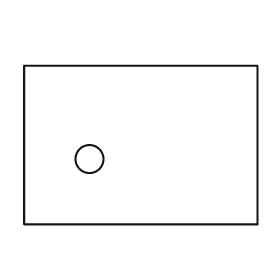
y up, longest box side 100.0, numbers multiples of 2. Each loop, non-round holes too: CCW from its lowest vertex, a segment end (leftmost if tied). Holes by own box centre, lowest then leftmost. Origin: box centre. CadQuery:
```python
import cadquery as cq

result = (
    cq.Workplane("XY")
    .moveTo(-50.0, -34.0)
    .lineTo(50.0, -34.0)
    .lineTo(50.0, 34.0)
    .lineTo(-50.0, 34.0)
    .close()
    .moveTo(-22.0, -6.0)
    .circle(6.0)
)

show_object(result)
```